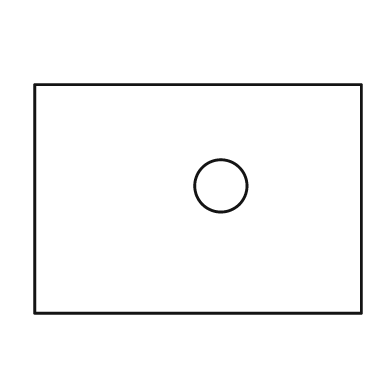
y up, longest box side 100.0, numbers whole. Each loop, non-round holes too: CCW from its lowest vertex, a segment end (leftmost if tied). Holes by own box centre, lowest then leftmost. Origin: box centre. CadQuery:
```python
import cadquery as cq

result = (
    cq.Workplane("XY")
    .moveTo(-50.0, -35.0)
    .lineTo(50.0, -35.0)
    .lineTo(50.0, 35.0)
    .lineTo(-50.0, 35.0)
    .close()
    .moveTo(7.0, 4.0)
    .circle(8.0)
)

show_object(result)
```